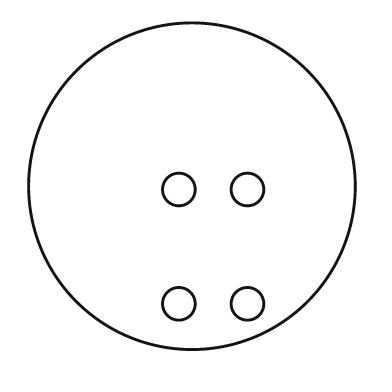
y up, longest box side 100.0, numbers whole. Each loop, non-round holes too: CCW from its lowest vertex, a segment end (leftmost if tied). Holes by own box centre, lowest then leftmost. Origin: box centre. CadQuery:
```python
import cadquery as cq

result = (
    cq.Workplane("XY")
    .moveTo(0.0, 0.0)
    .circle(50.0)
    .moveTo(-4.0, -36.0)
    .circle(5.0)
    .moveTo(17.0, -36.0)
    .circle(5.0)
    .moveTo(-4.0, -1.0)
    .circle(5.0)
    .moveTo(17.0, -1.0)
    .circle(5.0)
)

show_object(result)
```